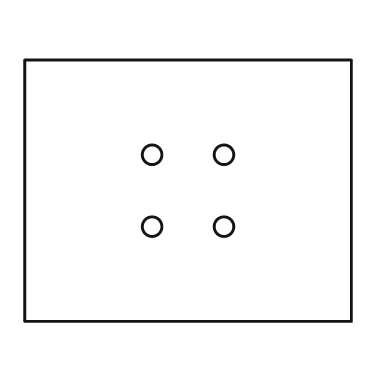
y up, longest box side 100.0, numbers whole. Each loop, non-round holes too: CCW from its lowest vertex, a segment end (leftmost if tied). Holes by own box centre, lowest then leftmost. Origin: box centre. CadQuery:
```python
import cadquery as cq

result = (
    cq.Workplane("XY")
    .moveTo(-50.0, -40.0)
    .lineTo(50.0, -40.0)
    .lineTo(50.0, 40.0)
    .lineTo(-50.0, 40.0)
    .close()
    .moveTo(-11.0, -11.0)
    .circle(3.0)
    .moveTo(11.0, -11.0)
    .circle(3.0)
    .moveTo(-11.0, 11.0)
    .circle(3.0)
    .moveTo(11.0, 11.0)
    .circle(3.0)
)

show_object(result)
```